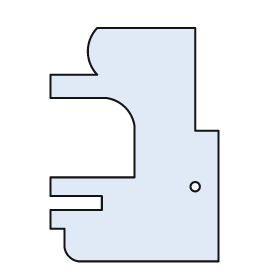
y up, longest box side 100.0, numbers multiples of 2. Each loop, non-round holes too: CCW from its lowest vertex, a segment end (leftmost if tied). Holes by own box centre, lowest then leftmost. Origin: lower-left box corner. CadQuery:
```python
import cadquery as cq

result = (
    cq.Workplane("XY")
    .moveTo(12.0, 0.0)
    .lineTo(72.0, 0.0)
    .lineTo(72.0, 56.0)
    .lineTo(62.0, 56.0)
    .lineTo(62.0, 100.0)
    .lineTo(20.0, 100.0)
    .threePointArc((16.0, 90.0), (20.0, 80.0))
    .lineTo(0.0, 80.0)
    .lineTo(0.0, 70.0)
    .lineTo(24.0, 70.0)
    .threePointArc((32.0, 66.0), (36.0, 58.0))
    .lineTo(36.0, 36.0)
    .lineTo(0.0, 36.0)
    .lineTo(0.0, 28.0)
    .lineTo(22.0, 28.0)
    .lineTo(22.0, 22.0)
    .lineTo(0.0, 22.0)
    .lineTo(0.0, 14.0)
    .lineTo(6.0, 14.0)
    .lineTo(6.0, 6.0)
    .threePointArc((8.0, 2.0), (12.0, 0.0))
    .close()
    .moveTo(62.0, 32.0)
    .circle(2.0)
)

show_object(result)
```